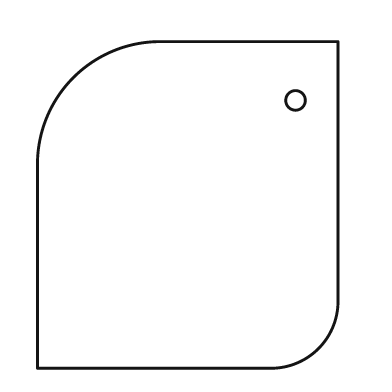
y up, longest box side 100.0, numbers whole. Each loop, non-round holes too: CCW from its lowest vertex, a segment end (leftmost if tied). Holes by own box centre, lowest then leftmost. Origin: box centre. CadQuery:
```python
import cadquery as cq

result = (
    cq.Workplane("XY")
    .moveTo(-46.0, -50.0)
    .lineTo(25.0, -50.0)
    .threePointArc((40.0, -44.0), (46.0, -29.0))
    .lineTo(46.0, 50.0)
    .lineTo(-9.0, 50.0)
    .threePointArc((-35.0, 39.0), (-46.0, 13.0))
    .close()
    .moveTo(33.0, 32.0)
    .circle(3.0)
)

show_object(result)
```